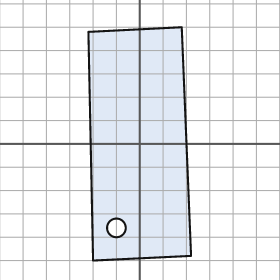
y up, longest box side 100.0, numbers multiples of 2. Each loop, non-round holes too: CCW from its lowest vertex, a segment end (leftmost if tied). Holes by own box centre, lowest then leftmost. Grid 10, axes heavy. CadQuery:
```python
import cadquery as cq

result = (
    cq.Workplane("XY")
    .moveTo(-20.0, -50.0)
    .lineTo(22.0, -48.0)
    .lineTo(18.0, 50.0)
    .lineTo(-22.0, 48.0)
    .close()
    .moveTo(-10.0, -36.0)
    .circle(4.0)
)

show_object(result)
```